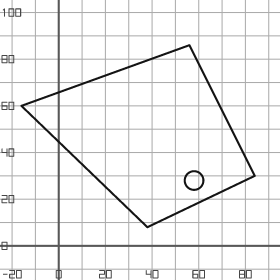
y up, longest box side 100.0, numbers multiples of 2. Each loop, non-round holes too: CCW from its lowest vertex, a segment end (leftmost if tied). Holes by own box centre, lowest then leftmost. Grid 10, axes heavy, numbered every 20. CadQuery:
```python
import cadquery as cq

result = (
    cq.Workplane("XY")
    .moveTo(38.0, 8.0)
    .lineTo(84.0, 30.0)
    .lineTo(56.0, 86.0)
    .lineTo(-16.0, 60.0)
    .close()
    .moveTo(58.0, 28.0)
    .circle(4.0)
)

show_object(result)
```